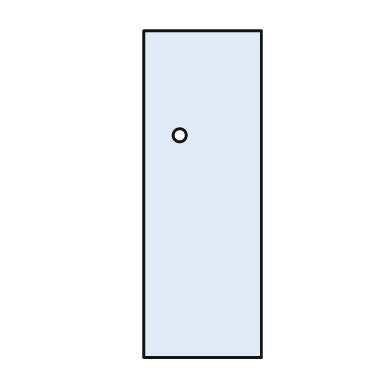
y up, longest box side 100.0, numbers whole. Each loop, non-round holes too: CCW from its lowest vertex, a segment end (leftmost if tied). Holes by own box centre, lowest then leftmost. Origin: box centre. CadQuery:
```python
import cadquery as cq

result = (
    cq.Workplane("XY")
    .moveTo(-18.0, -50.0)
    .lineTo(18.0, -50.0)
    .lineTo(18.0, 50.0)
    .lineTo(-18.0, 50.0)
    .close()
    .moveTo(-7.0, 18.0)
    .circle(2.0)
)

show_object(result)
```